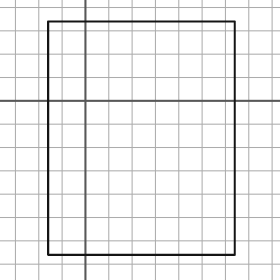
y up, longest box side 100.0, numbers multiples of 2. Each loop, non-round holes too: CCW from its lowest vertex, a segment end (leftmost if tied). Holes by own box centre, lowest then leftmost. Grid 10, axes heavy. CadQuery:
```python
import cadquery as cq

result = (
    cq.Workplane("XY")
    .moveTo(-16.0, -66.0)
    .lineTo(64.0, -66.0)
    .lineTo(64.0, 34.0)
    .lineTo(-16.0, 34.0)
    .close()
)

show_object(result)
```